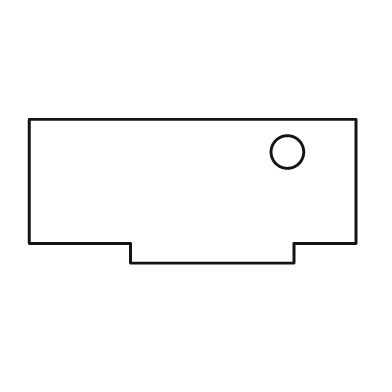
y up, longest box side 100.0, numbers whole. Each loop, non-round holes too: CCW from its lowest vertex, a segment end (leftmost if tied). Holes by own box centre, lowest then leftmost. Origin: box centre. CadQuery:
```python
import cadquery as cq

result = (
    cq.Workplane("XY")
    .moveTo(-19.0, -22.0)
    .lineTo(31.0, -22.0)
    .lineTo(31.0, -16.0)
    .lineTo(50.0, -16.0)
    .lineTo(50.0, 22.0)
    .lineTo(-50.0, 22.0)
    .lineTo(-50.0, -16.0)
    .lineTo(-19.0, -16.0)
    .close()
    .moveTo(29.0, 12.0)
    .circle(5.0)
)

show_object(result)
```